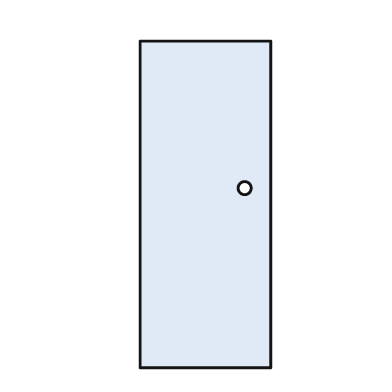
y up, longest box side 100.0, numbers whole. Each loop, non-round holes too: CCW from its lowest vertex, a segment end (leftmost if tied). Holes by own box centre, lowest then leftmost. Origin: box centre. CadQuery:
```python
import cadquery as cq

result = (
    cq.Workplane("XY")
    .moveTo(-20.0, -50.0)
    .lineTo(20.0, -50.0)
    .lineTo(20.0, 50.0)
    .lineTo(-20.0, 50.0)
    .close()
    .moveTo(12.0, 5.0)
    .circle(2.0)
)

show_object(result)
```